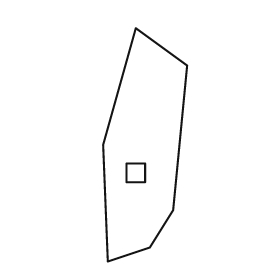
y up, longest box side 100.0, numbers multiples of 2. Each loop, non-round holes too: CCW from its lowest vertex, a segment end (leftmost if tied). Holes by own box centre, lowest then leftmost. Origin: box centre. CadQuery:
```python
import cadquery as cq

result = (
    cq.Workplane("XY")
    .moveTo(-16.0, -50.0)
    .lineTo(2.0, -44.0)
    .lineTo(12.0, -28.0)
    .lineTo(18.0, 34.0)
    .lineTo(-4.0, 50.0)
    .lineTo(-18.0, 0.0)
    .close()
    .moveTo(-8.0, -16.0)
    .lineTo(0.0, -16.0)
    .lineTo(0.0, -8.0)
    .lineTo(-8.0, -8.0)
    .close()
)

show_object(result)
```